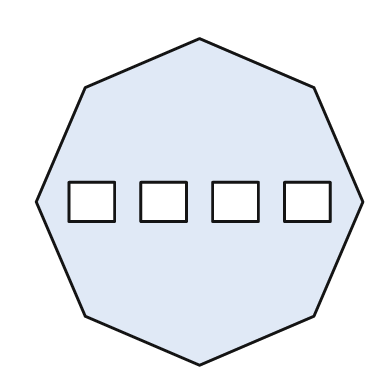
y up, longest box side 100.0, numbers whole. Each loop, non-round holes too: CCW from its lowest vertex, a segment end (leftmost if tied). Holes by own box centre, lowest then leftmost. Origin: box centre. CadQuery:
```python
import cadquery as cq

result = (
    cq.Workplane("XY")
    .moveTo(0.0, -50.0)
    .lineTo(35.0, -35.0)
    .lineTo(50.0, 0.0)
    .lineTo(35.0, 35.0)
    .lineTo(0.0, 50.0)
    .lineTo(-35.0, 35.0)
    .lineTo(-50.0, 0.0)
    .lineTo(-35.0, -35.0)
    .close()
    .moveTo(-40.0, -6.0)
    .lineTo(-26.0, -6.0)
    .lineTo(-26.0, 6.0)
    .lineTo(-40.0, 6.0)
    .close()
    .moveTo(-18.0, -6.0)
    .lineTo(-4.0, -6.0)
    .lineTo(-4.0, 6.0)
    .lineTo(-18.0, 6.0)
    .close()
    .moveTo(4.0, -6.0)
    .lineTo(18.0, -6.0)
    .lineTo(18.0, 6.0)
    .lineTo(4.0, 6.0)
    .close()
    .moveTo(26.0, -6.0)
    .lineTo(40.0, -6.0)
    .lineTo(40.0, 6.0)
    .lineTo(26.0, 6.0)
    .close()
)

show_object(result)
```